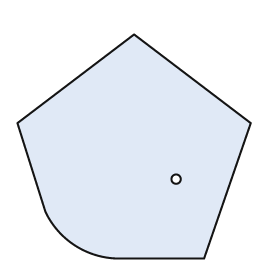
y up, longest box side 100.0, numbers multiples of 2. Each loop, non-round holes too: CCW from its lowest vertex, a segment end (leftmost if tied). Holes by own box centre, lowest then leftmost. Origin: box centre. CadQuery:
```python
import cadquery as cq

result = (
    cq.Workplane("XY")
    .moveTo(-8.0, -48.0)
    .lineTo(30.0, -48.0)
    .lineTo(50.0, 10.0)
    .lineTo(0.0, 48.0)
    .lineTo(-50.0, 10.0)
    .lineTo(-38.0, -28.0)
    .threePointArc((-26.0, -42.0), (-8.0, -48.0))
    .close()
    .moveTo(18.0, -14.0)
    .circle(2.0)
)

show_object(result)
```